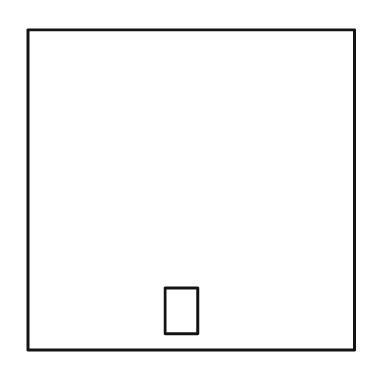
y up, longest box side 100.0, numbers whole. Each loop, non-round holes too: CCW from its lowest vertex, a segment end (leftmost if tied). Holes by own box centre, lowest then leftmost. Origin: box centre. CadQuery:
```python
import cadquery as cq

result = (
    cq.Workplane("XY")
    .moveTo(-50.0, -49.0)
    .lineTo(50.0, -49.0)
    .lineTo(50.0, 49.0)
    .lineTo(-50.0, 49.0)
    .close()
    .moveTo(-8.0, -44.0)
    .lineTo(2.0, -44.0)
    .lineTo(2.0, -30.0)
    .lineTo(-8.0, -30.0)
    .close()
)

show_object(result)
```